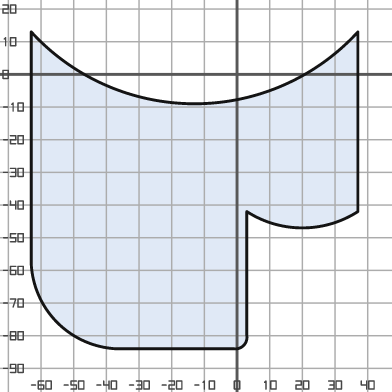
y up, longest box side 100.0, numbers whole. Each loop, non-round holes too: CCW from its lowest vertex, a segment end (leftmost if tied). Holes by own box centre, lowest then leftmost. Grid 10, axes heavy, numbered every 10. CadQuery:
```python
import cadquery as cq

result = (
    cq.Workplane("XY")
    .moveTo(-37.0, -84.0)
    .lineTo(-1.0, -84.0)
    .threePointArc((2.0, -83.0), (3.0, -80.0))
    .lineTo(3.0, -42.0)
    .threePointArc((20.0, -47.0), (37.0, -42.0))
    .lineTo(37.0, 13.0)
    .threePointArc((-13.0, -9.0), (-63.0, 13.0))
    .lineTo(-63.0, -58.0)
    .threePointArc((-55.0, -76.0), (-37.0, -84.0))
    .close()
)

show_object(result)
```